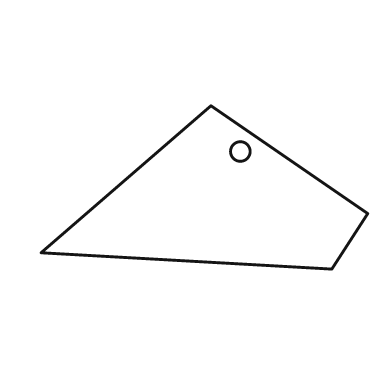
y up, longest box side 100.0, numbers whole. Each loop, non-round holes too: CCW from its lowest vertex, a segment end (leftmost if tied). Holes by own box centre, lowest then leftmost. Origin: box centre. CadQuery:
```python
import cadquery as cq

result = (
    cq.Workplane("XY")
    .moveTo(39.0, -25.0)
    .lineTo(50.0, -8.0)
    .lineTo(2.0, 25.0)
    .lineTo(-50.0, -20.0)
    .close()
    .moveTo(11.0, 11.0)
    .circle(3.0)
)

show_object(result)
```